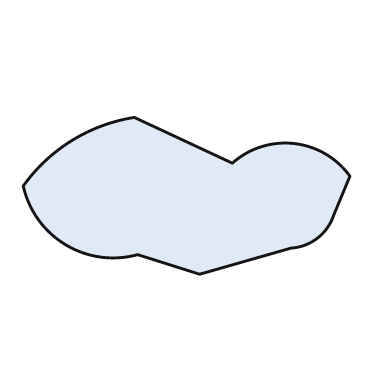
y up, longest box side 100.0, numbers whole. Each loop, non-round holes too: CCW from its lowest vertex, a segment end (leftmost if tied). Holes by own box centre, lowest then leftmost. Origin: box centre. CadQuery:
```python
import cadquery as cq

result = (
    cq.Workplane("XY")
    .moveTo(4.0, -24.0)
    .lineTo(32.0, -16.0)
    .threePointArc((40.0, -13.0), (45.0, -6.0))
    .lineTo(50.0, 6.0)
    .threePointArc((33.0, 16.0), (14.0, 10.0))
    .lineTo(-16.0, 24.0)
    .threePointArc((-35.0, 17.0), (-50.0, 3.0))
    .threePointArc((-37.0, -15.0), (-15.0, -18.0))
    .close()
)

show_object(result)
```